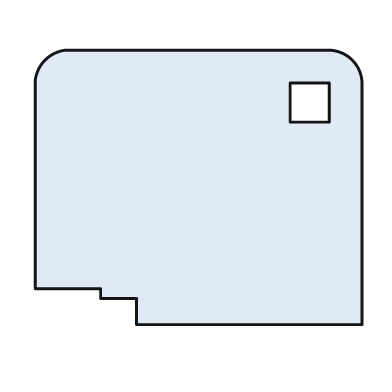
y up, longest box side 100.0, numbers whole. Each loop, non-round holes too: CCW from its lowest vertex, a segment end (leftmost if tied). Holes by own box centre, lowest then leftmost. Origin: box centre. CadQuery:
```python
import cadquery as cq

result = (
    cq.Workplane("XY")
    .moveTo(-19.0, -42.0)
    .lineTo(50.0, -42.0)
    .lineTo(50.0, 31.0)
    .threePointArc((47.0, 39.0), (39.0, 42.0))
    .lineTo(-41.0, 42.0)
    .threePointArc((-47.0, 39.0), (-50.0, 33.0))
    .lineTo(-50.0, -31.0)
    .lineTo(-30.0, -31.0)
    .lineTo(-30.0, -34.0)
    .lineTo(-19.0, -34.0)
    .close()
    .moveTo(28.0, 20.0)
    .lineTo(40.0, 20.0)
    .lineTo(40.0, 32.0)
    .lineTo(28.0, 32.0)
    .close()
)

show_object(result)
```